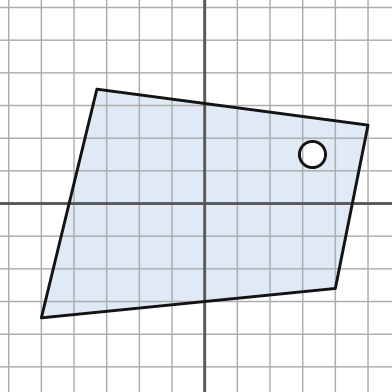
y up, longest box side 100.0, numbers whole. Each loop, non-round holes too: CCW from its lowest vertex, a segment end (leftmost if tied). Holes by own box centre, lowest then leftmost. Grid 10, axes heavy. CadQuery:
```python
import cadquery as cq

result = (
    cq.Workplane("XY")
    .moveTo(-50.0, -35.0)
    .lineTo(40.0, -26.0)
    .lineTo(50.0, 24.0)
    .lineTo(-33.0, 35.0)
    .close()
    .moveTo(33.0, 15.0)
    .circle(4.0)
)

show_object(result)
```